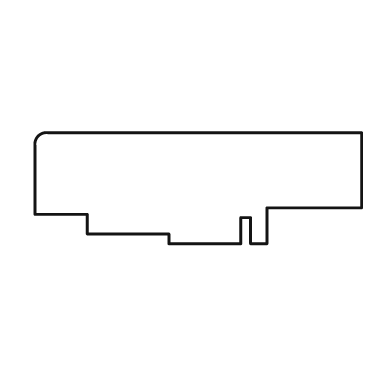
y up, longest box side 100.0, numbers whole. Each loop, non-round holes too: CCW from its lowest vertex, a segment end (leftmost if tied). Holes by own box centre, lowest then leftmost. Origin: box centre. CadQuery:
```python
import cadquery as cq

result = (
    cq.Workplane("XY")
    .moveTo(-9.0, -17.0)
    .lineTo(13.0, -17.0)
    .lineTo(13.0, -9.0)
    .lineTo(16.0, -9.0)
    .lineTo(16.0, -17.0)
    .lineTo(21.0, -17.0)
    .lineTo(21.0, -6.0)
    .lineTo(50.0, -6.0)
    .lineTo(50.0, 17.0)
    .lineTo(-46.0, 17.0)
    .threePointArc((-49.0, 16.0), (-50.0, 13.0))
    .lineTo(-50.0, -8.0)
    .lineTo(-34.0, -8.0)
    .lineTo(-34.0, -14.0)
    .lineTo(-9.0, -14.0)
    .close()
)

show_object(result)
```